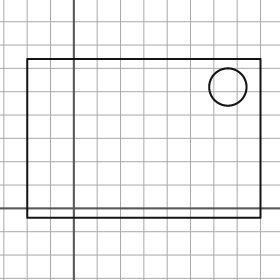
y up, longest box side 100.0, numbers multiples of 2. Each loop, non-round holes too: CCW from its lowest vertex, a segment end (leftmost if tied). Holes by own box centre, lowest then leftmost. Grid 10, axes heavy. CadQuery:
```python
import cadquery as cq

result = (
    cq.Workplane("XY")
    .moveTo(-20.0, -4.0)
    .lineTo(80.0, -4.0)
    .lineTo(80.0, 64.0)
    .lineTo(-20.0, 64.0)
    .close()
    .moveTo(66.0, 52.0)
    .circle(8.0)
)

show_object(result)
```